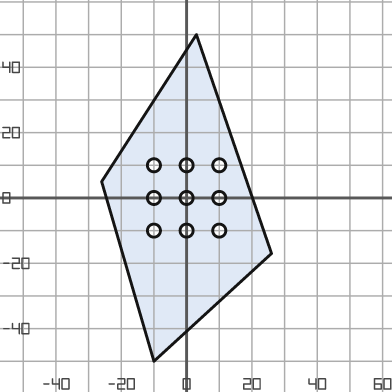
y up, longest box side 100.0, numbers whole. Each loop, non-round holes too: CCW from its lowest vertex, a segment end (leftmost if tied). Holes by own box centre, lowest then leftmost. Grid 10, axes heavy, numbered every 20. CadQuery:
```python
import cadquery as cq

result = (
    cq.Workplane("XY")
    .moveTo(-10.0, -50.0)
    .lineTo(26.0, -17.0)
    .lineTo(3.0, 50.0)
    .lineTo(-26.0, 5.0)
    .close()
    .moveTo(-10.0, -10.0)
    .circle(2.0)
    .moveTo(0.0, -10.0)
    .circle(2.0)
    .moveTo(10.0, -10.0)
    .circle(2.0)
    .moveTo(-10.0, 0.0)
    .circle(2.0)
    .moveTo(0.0, 0.0)
    .circle(2.0)
    .moveTo(10.0, 0.0)
    .circle(2.0)
    .moveTo(-10.0, 10.0)
    .circle(2.0)
    .moveTo(0.0, 10.0)
    .circle(2.0)
    .moveTo(10.0, 10.0)
    .circle(2.0)
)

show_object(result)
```